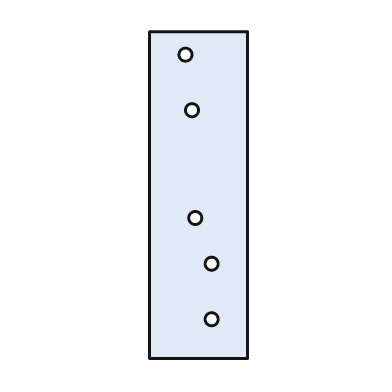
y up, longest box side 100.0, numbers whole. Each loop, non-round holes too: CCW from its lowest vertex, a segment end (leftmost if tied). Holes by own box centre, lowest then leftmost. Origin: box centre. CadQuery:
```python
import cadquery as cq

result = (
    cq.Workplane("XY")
    .moveTo(-15.0, -50.0)
    .lineTo(15.0, -50.0)
    .lineTo(15.0, 50.0)
    .lineTo(-15.0, 50.0)
    .close()
    .moveTo(4.0, -38.0)
    .circle(2.0)
    .moveTo(4.0, -21.0)
    .circle(2.0)
    .moveTo(-1.0, -7.0)
    .circle(2.0)
    .moveTo(-2.0, 26.0)
    .circle(2.0)
    .moveTo(-4.0, 43.0)
    .circle(2.0)
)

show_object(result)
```